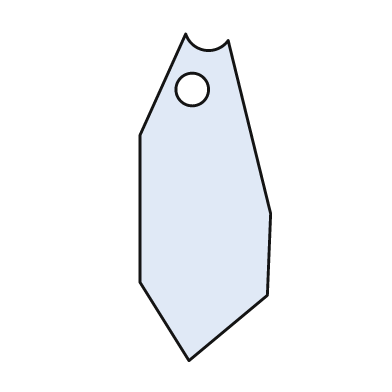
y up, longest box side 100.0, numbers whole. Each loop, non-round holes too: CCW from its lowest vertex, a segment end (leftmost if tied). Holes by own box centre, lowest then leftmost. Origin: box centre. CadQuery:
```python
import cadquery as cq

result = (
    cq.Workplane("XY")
    .moveTo(-5.0, -50.0)
    .lineTo(19.0, -30.0)
    .lineTo(20.0, -5.0)
    .lineTo(7.0, 48.0)
    .threePointArc((0.0, 45.0), (-6.0, 50.0))
    .lineTo(-20.0, 19.0)
    .lineTo(-20.0, -26.0)
    .close()
    .moveTo(-4.0, 33.0)
    .circle(5.0)
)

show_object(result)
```